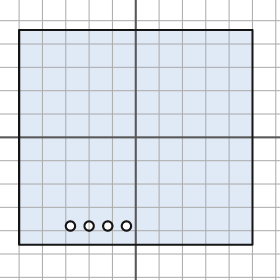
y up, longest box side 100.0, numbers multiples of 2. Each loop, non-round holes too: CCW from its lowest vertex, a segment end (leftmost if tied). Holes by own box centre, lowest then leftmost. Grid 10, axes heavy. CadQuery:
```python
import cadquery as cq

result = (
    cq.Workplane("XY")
    .moveTo(-50.0, -46.0)
    .lineTo(50.0, -46.0)
    .lineTo(50.0, 46.0)
    .lineTo(-50.0, 46.0)
    .close()
    .moveTo(-28.0, -38.0)
    .circle(2.0)
    .moveTo(-20.0, -38.0)
    .circle(2.0)
    .moveTo(-12.0, -38.0)
    .circle(2.0)
    .moveTo(-4.0, -38.0)
    .circle(2.0)
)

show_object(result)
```